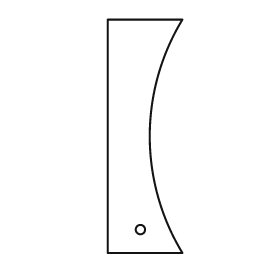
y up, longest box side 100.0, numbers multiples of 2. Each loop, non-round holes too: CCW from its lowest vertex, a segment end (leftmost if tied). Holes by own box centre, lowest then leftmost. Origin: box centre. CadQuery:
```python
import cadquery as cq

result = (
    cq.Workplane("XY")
    .moveTo(-16.0, -50.0)
    .lineTo(16.0, -50.0)
    .threePointArc((2.0, 0.0), (16.0, 50.0))
    .lineTo(-16.0, 50.0)
    .close()
    .moveTo(-2.0, -40.0)
    .circle(2.0)
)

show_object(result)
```